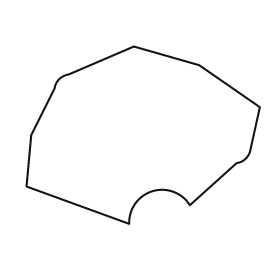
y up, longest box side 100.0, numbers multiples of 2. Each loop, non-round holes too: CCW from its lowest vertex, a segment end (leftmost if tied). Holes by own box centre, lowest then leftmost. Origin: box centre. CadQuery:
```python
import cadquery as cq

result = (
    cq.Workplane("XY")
    .moveTo(-6.0, -38.0)
    .threePointArc((4.0, -24.0), (20.0, -30.0))
    .lineTo(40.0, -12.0)
    .threePointArc((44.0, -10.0), (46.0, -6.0))
    .lineTo(50.0, 12.0)
    .lineTo(24.0, 30.0)
    .lineTo(-4.0, 38.0)
    .lineTo(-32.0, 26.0)
    .threePointArc((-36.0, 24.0), (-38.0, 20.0))
    .lineTo(-48.0, 0.0)
    .lineTo(-50.0, -22.0)
    .close()
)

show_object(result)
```